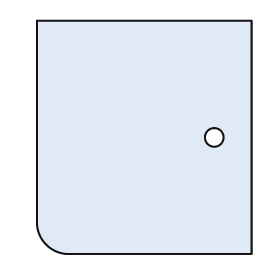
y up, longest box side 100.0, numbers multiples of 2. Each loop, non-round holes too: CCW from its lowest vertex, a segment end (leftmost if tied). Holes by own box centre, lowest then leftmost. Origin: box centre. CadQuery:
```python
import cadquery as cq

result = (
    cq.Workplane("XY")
    .moveTo(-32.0, -50.0)
    .lineTo(46.0, -50.0)
    .lineTo(46.0, 50.0)
    .lineTo(-46.0, 50.0)
    .lineTo(-46.0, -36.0)
    .threePointArc((-42.0, -46.0), (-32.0, -50.0))
    .close()
    .moveTo(30.0, 0.0)
    .circle(4.0)
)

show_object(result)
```